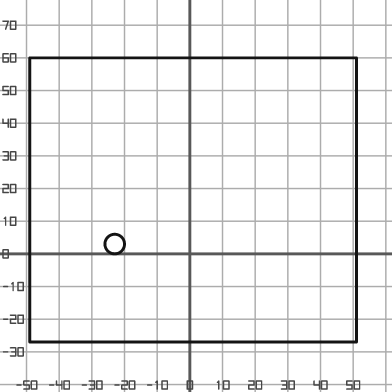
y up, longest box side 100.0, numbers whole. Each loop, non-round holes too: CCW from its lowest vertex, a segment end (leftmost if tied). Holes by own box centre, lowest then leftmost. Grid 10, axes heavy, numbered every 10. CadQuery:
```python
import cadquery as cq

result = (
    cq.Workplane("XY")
    .moveTo(-49.0, -27.0)
    .lineTo(51.0, -27.0)
    .lineTo(51.0, 60.0)
    .lineTo(-49.0, 60.0)
    .close()
    .moveTo(-23.0, 3.0)
    .circle(3.0)
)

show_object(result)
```